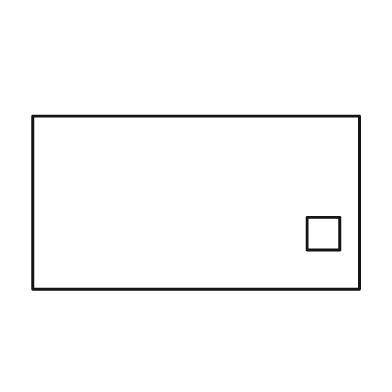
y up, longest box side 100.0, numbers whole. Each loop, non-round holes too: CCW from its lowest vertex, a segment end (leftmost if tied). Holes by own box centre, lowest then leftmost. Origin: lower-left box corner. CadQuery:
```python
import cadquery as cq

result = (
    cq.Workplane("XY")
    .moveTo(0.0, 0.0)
    .lineTo(100.0, 0.0)
    .lineTo(100.0, 53.0)
    .lineTo(0.0, 53.0)
    .close()
    .moveTo(84.0, 12.0)
    .lineTo(94.0, 12.0)
    .lineTo(94.0, 22.0)
    .lineTo(84.0, 22.0)
    .close()
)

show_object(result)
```